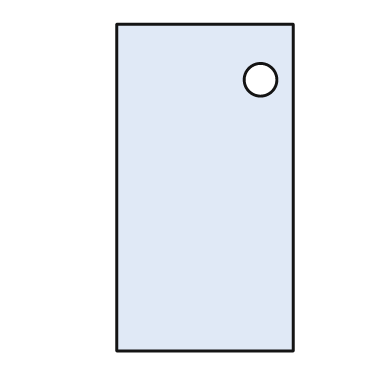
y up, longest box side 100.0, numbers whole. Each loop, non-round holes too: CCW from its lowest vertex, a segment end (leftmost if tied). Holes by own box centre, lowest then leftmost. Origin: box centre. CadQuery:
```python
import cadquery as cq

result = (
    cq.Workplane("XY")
    .moveTo(-27.0, -50.0)
    .lineTo(27.0, -50.0)
    .lineTo(27.0, 50.0)
    .lineTo(-27.0, 50.0)
    .close()
    .moveTo(17.0, 33.0)
    .circle(5.0)
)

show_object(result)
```